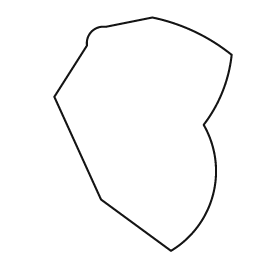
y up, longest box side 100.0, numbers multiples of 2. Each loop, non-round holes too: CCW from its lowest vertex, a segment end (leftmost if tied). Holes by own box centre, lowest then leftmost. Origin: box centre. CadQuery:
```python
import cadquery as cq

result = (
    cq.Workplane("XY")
    .moveTo(12.0, -50.0)
    .threePointArc((30.0, -26.0), (26.0, 4.0))
    .threePointArc((34.0, 18.0), (38.0, 34.0))
    .threePointArc((22.0, 44.0), (4.0, 50.0))
    .lineTo(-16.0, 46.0)
    .threePointArc((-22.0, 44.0), (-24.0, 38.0))
    .lineTo(-38.0, 16.0)
    .lineTo(-18.0, -28.0)
    .close()
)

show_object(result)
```